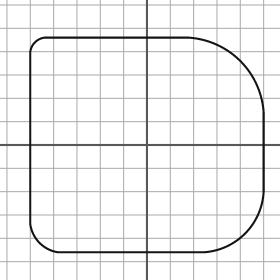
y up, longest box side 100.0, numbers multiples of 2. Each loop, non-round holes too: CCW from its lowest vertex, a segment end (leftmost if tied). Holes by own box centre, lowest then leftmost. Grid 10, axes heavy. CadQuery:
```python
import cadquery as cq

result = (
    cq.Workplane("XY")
    .moveTo(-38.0, -46.0)
    .lineTo(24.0, -46.0)
    .threePointArc((42.0, -38.0), (50.0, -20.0))
    .lineTo(50.0, 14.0)
    .threePointArc((40.0, 36.0), (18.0, 46.0))
    .lineTo(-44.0, 46.0)
    .threePointArc((-48.0, 44.0), (-50.0, 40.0))
    .lineTo(-50.0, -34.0)
    .threePointArc((-46.0, -42.0), (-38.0, -46.0))
    .close()
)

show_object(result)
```